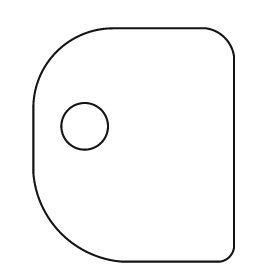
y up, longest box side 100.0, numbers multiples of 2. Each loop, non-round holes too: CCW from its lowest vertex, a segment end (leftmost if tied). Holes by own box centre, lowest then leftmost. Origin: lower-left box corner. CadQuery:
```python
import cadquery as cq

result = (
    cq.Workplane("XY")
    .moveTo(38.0, 0.0)
    .lineTo(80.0, 0.0)
    .threePointArc((84.0, 2.0), (86.0, 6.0))
    .lineTo(86.0, 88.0)
    .threePointArc((82.0, 96.0), (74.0, 100.0))
    .lineTo(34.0, 100.0)
    .threePointArc((10.0, 90.0), (0.0, 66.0))
    .lineTo(0.0, 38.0)
    .threePointArc((12.0, 12.0), (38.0, 0.0))
    .close()
    .moveTo(22.0, 58.0)
    .circle(10.0)
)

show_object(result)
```